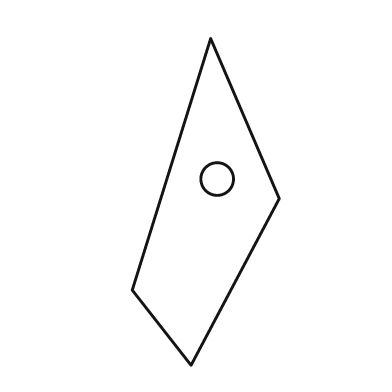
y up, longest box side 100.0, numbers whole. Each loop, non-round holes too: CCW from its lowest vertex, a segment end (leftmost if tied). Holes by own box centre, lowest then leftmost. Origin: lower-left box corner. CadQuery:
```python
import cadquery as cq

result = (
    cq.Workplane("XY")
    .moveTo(18.0, 0.0)
    .lineTo(45.0, 51.0)
    .lineTo(24.0, 100.0)
    .lineTo(0.0, 23.0)
    .close()
    .moveTo(26.0, 57.0)
    .circle(5.0)
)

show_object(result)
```